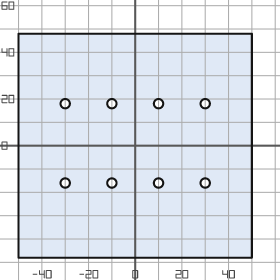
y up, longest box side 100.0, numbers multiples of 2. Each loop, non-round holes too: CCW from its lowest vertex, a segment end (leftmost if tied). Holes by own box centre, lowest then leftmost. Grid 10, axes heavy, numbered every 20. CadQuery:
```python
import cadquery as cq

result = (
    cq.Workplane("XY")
    .moveTo(-50.0, -48.0)
    .lineTo(50.0, -48.0)
    .lineTo(50.0, 48.0)
    .lineTo(-50.0, 48.0)
    .close()
    .moveTo(-30.0, -16.0)
    .circle(2.0)
    .moveTo(-10.0, -16.0)
    .circle(2.0)
    .moveTo(10.0, -16.0)
    .circle(2.0)
    .moveTo(30.0, -16.0)
    .circle(2.0)
    .moveTo(-30.0, 18.0)
    .circle(2.0)
    .moveTo(-10.0, 18.0)
    .circle(2.0)
    .moveTo(10.0, 18.0)
    .circle(2.0)
    .moveTo(30.0, 18.0)
    .circle(2.0)
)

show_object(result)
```